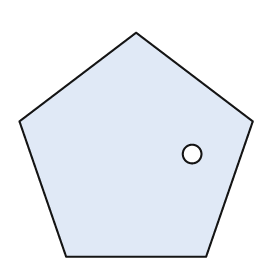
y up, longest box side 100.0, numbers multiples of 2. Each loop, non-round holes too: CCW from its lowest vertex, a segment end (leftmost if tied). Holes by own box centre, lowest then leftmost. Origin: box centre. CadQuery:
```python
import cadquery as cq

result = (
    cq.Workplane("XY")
    .moveTo(-30.0, -48.0)
    .lineTo(30.0, -48.0)
    .lineTo(50.0, 10.0)
    .lineTo(0.0, 48.0)
    .lineTo(-50.0, 10.0)
    .close()
    .moveTo(24.0, -4.0)
    .circle(4.0)
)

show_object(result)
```